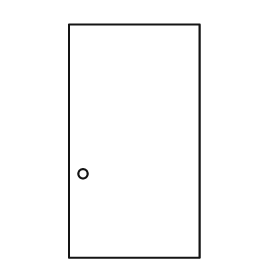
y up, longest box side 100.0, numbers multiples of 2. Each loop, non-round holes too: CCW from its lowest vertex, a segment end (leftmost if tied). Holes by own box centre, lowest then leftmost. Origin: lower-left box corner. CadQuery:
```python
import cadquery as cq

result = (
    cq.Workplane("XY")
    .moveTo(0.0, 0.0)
    .lineTo(56.0, 0.0)
    .lineTo(56.0, 100.0)
    .lineTo(0.0, 100.0)
    .close()
    .moveTo(6.0, 36.0)
    .circle(2.0)
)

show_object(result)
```